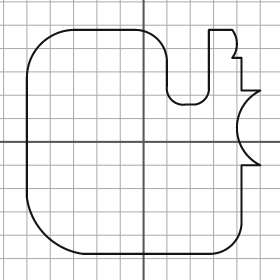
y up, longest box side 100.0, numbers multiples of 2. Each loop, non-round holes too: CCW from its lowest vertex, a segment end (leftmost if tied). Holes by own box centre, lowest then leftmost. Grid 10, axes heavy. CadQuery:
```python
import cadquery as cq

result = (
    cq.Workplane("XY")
    .moveTo(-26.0, -48.0)
    .lineTo(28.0, -48.0)
    .threePointArc((38.0, -44.0), (42.0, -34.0))
    .lineTo(42.0, -10.0)
    .lineTo(50.0, -10.0)
    .threePointArc((40.0, 6.0), (50.0, 22.0))
    .lineTo(42.0, 22.0)
    .lineTo(42.0, 36.0)
    .lineTo(38.0, 36.0)
    .threePointArc((40.0, 42.0), (38.0, 48.0))
    .lineTo(28.0, 48.0)
    .lineTo(28.0, 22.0)
    .threePointArc((26.0, 18.0), (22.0, 16.0))
    .lineTo(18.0, 16.0)
    .threePointArc((12.0, 18.0), (10.0, 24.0))
    .lineTo(10.0, 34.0)
    .threePointArc((6.0, 44.0), (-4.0, 48.0))
    .lineTo(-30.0, 48.0)
    .threePointArc((-44.0, 42.0), (-50.0, 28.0))
    .lineTo(-50.0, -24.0)
    .threePointArc((-42.0, -40.0), (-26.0, -48.0))
    .close()
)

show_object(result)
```